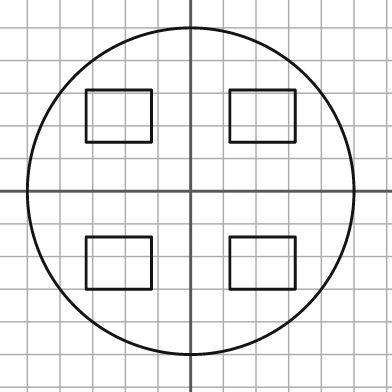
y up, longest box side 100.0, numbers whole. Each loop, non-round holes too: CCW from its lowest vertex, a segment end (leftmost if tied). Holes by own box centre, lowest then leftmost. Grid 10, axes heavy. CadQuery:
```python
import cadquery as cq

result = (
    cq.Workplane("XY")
    .moveTo(0.0, 0.0)
    .circle(50.0)
    .moveTo(-32.0, -30.0)
    .lineTo(-12.0, -30.0)
    .lineTo(-12.0, -14.0)
    .lineTo(-32.0, -14.0)
    .close()
    .moveTo(12.0, -30.0)
    .lineTo(32.0, -30.0)
    .lineTo(32.0, -14.0)
    .lineTo(12.0, -14.0)
    .close()
    .moveTo(-32.0, 15.0)
    .lineTo(-12.0, 15.0)
    .lineTo(-12.0, 31.0)
    .lineTo(-32.0, 31.0)
    .close()
    .moveTo(12.0, 15.0)
    .lineTo(32.0, 15.0)
    .lineTo(32.0, 31.0)
    .lineTo(12.0, 31.0)
    .close()
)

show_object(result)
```